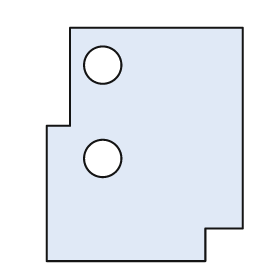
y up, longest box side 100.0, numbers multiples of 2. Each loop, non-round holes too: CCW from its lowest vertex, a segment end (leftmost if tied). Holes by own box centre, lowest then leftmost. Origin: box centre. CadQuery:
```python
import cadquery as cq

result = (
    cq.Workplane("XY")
    .moveTo(-42.0, -50.0)
    .lineTo(26.0, -50.0)
    .lineTo(26.0, -36.0)
    .lineTo(42.0, -36.0)
    .lineTo(42.0, 50.0)
    .lineTo(-32.0, 50.0)
    .lineTo(-32.0, 8.0)
    .lineTo(-42.0, 8.0)
    .close()
    .moveTo(-18.0, -6.0)
    .circle(8.0)
    .moveTo(-18.0, 34.0)
    .circle(8.0)
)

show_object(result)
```